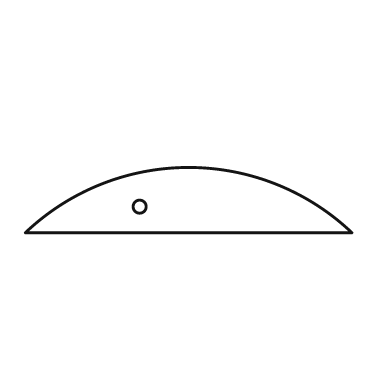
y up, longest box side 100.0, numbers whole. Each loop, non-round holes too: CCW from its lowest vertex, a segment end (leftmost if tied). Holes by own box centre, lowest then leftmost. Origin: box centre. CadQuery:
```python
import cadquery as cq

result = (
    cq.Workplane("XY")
    .moveTo(-50.0, -10.0)
    .lineTo(50.0, -10.0)
    .threePointArc((0.0, 10.0), (-50.0, -10.0))
    .close()
    .moveTo(-15.0, -2.0)
    .circle(2.0)
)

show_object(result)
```